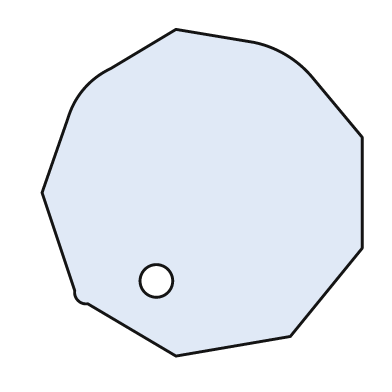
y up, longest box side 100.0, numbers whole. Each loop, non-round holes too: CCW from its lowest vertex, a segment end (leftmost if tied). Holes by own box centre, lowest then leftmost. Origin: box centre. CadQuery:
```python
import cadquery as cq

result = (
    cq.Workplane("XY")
    .moveTo(-8.0, -50.0)
    .lineTo(27.0, -44.0)
    .lineTo(49.0, -17.0)
    .lineTo(49.0, 17.0)
    .lineTo(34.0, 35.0)
    .threePointArc((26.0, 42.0), (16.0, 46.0))
    .lineTo(-8.0, 50.0)
    .lineTo(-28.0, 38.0)
    .threePointArc((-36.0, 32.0), (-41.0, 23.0))
    .lineTo(-49.0, 0.0)
    .lineTo(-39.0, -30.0)
    .threePointArc((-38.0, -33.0), (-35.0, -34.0))
    .close()
    .moveTo(-14.0, -27.0)
    .circle(5.0)
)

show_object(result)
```